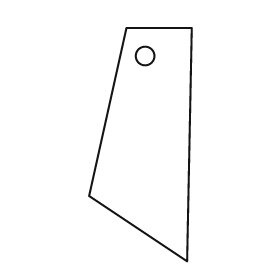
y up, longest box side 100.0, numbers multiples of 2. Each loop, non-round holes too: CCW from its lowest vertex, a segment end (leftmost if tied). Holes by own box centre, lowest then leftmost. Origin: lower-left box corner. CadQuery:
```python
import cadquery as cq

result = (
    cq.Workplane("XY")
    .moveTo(42.0, 0.0)
    .lineTo(44.0, 100.0)
    .lineTo(16.0, 100.0)
    .lineTo(0.0, 28.0)
    .close()
    .moveTo(24.0, 88.0)
    .circle(4.0)
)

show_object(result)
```